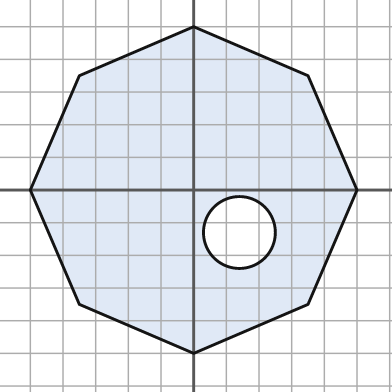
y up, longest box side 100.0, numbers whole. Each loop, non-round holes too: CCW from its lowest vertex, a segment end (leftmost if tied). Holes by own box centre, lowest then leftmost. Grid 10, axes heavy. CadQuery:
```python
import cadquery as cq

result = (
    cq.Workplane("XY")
    .moveTo(0.0, -50.0)
    .lineTo(35.0, -35.0)
    .lineTo(50.0, 0.0)
    .lineTo(35.0, 35.0)
    .lineTo(0.0, 50.0)
    .lineTo(-35.0, 35.0)
    .lineTo(-50.0, 0.0)
    .lineTo(-35.0, -35.0)
    .close()
    .moveTo(14.0, -13.0)
    .circle(11.0)
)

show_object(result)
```